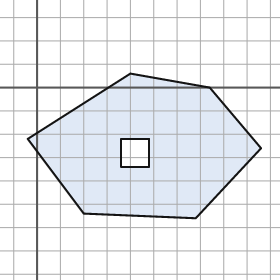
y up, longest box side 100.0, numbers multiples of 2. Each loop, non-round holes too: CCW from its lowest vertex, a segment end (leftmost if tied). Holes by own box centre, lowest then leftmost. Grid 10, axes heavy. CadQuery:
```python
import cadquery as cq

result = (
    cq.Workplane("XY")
    .moveTo(68.0, -56.0)
    .lineTo(96.0, -26.0)
    .lineTo(74.0, 0.0)
    .lineTo(40.0, 6.0)
    .lineTo(-4.0, -22.0)
    .lineTo(20.0, -54.0)
    .close()
    .moveTo(36.0, -34.0)
    .lineTo(48.0, -34.0)
    .lineTo(48.0, -22.0)
    .lineTo(36.0, -22.0)
    .close()
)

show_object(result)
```